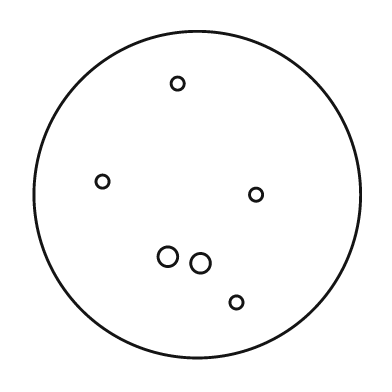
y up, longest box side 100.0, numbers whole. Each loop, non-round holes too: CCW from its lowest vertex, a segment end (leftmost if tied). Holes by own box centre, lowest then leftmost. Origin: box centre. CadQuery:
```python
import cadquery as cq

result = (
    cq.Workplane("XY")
    .moveTo(0.0, 0.0)
    .circle(50.0)
    .moveTo(12.0, -33.0)
    .circle(2.0)
    .moveTo(1.0, -21.0)
    .circle(3.0)
    .moveTo(-9.0, -19.0)
    .circle(3.0)
    .moveTo(18.0, 0.0)
    .circle(2.0)
    .moveTo(-29.0, 4.0)
    .circle(2.0)
    .moveTo(-6.0, 34.0)
    .circle(2.0)
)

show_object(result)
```